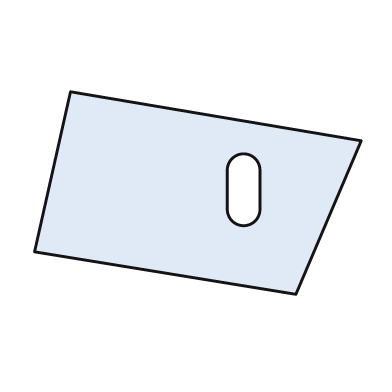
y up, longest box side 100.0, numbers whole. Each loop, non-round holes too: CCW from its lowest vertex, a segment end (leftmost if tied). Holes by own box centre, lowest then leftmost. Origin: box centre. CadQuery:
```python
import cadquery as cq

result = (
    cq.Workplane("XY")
    .moveTo(30.0, -31.0)
    .lineTo(50.0, 16.0)
    .lineTo(-39.0, 31.0)
    .lineTo(-50.0, -18.0)
    .close()
    .moveTo(9.0, -5.0)
    .threePointArc((14.0, -10.0), (19.0, -5.0))
    .lineTo(19.0, 7.0)
    .threePointArc((14.0, 12.0), (9.0, 7.0))
    .close()
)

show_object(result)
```